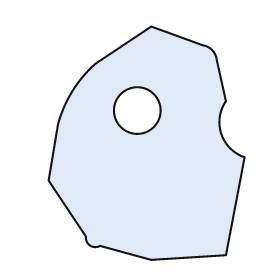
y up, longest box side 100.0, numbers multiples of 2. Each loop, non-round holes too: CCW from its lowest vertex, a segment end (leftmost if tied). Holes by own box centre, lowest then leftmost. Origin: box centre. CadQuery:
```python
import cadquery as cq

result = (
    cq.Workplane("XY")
    .moveTo(2.0, -50.0)
    .lineTo(34.0, -48.0)
    .lineTo(42.0, -6.0)
    .threePointArc((32.0, 4.0), (34.0, 18.0))
    .lineTo(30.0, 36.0)
    .threePointArc((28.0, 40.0), (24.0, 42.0))
    .lineTo(2.0, 50.0)
    .lineTo(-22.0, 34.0)
    .threePointArc((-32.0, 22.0), (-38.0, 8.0))
    .lineTo(-42.0, -16.0)
    .lineTo(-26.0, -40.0)
    .threePointArc((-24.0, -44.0), (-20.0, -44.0))
    .close()
    .moveTo(-4.0, 14.0)
    .circle(10.0)
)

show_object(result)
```